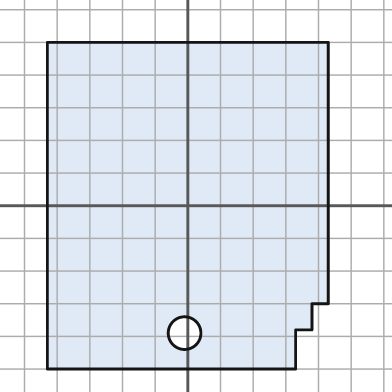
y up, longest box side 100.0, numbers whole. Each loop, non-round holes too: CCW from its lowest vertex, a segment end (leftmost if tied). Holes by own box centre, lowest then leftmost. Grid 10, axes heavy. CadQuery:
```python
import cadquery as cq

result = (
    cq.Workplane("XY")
    .moveTo(-43.0, -50.0)
    .lineTo(33.0, -50.0)
    .lineTo(33.0, -38.0)
    .lineTo(38.0, -38.0)
    .lineTo(38.0, -30.0)
    .lineTo(43.0, -30.0)
    .lineTo(43.0, 50.0)
    .lineTo(-43.0, 50.0)
    .close()
    .moveTo(-1.0, -39.0)
    .circle(5.0)
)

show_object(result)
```